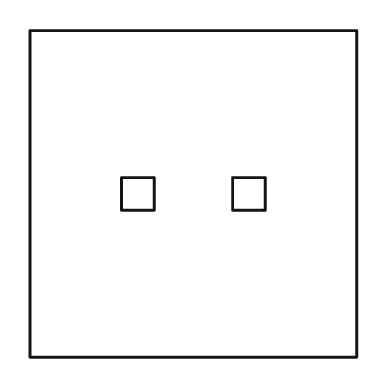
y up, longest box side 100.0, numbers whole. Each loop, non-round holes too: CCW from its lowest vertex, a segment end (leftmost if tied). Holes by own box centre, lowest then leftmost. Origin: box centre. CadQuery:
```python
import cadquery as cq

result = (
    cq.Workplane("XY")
    .moveTo(-50.0, -50.0)
    .lineTo(50.0, -50.0)
    .lineTo(50.0, 50.0)
    .lineTo(-50.0, 50.0)
    .close()
    .moveTo(-22.0, -5.0)
    .lineTo(-12.0, -5.0)
    .lineTo(-12.0, 5.0)
    .lineTo(-22.0, 5.0)
    .close()
    .moveTo(12.0, -5.0)
    .lineTo(22.0, -5.0)
    .lineTo(22.0, 5.0)
    .lineTo(12.0, 5.0)
    .close()
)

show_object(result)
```